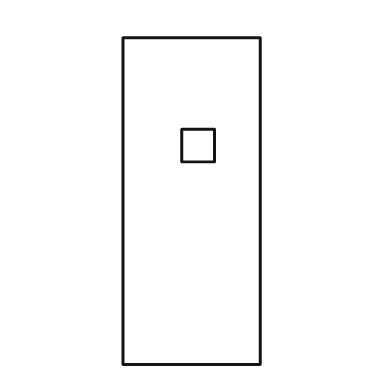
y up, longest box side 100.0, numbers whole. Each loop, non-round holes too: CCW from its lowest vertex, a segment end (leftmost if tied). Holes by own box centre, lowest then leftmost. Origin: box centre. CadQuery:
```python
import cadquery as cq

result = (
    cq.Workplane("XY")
    .moveTo(-21.0, -50.0)
    .lineTo(21.0, -50.0)
    .lineTo(21.0, 50.0)
    .lineTo(-21.0, 50.0)
    .close()
    .moveTo(-3.0, 12.0)
    .lineTo(7.0, 12.0)
    .lineTo(7.0, 22.0)
    .lineTo(-3.0, 22.0)
    .close()
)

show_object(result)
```